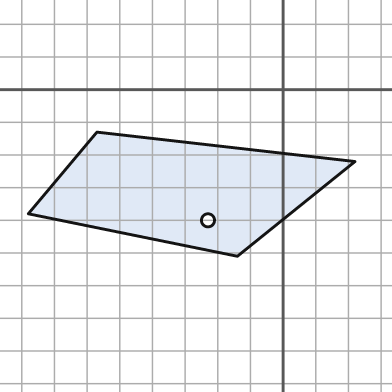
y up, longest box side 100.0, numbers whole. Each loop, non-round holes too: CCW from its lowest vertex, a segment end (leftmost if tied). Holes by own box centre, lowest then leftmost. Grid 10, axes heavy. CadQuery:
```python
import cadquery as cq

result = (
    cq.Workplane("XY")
    .moveTo(-14.0, -51.0)
    .lineTo(22.0, -22.0)
    .lineTo(-57.0, -13.0)
    .lineTo(-78.0, -38.0)
    .close()
    .moveTo(-23.0, -40.0)
    .circle(2.0)
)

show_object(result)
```